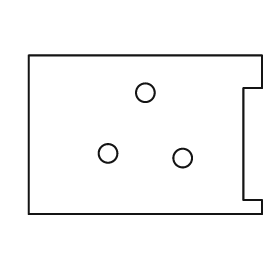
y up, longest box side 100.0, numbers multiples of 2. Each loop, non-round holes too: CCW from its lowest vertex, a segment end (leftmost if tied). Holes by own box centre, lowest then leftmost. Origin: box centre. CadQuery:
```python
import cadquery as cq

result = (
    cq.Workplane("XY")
    .moveTo(-50.0, -34.0)
    .lineTo(50.0, -34.0)
    .lineTo(50.0, -28.0)
    .lineTo(42.0, -28.0)
    .lineTo(42.0, 20.0)
    .lineTo(50.0, 20.0)
    .lineTo(50.0, 34.0)
    .lineTo(-50.0, 34.0)
    .close()
    .moveTo(16.0, -10.0)
    .circle(4.0)
    .moveTo(-16.0, -8.0)
    .circle(4.0)
    .moveTo(0.0, 18.0)
    .circle(4.0)
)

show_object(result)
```